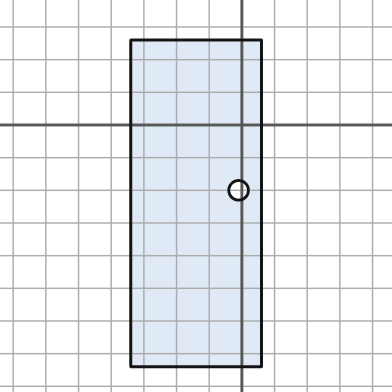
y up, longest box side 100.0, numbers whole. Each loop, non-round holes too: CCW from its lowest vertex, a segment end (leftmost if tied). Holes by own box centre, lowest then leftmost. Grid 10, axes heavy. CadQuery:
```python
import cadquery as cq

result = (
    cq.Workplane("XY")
    .moveTo(-34.0, -74.0)
    .lineTo(6.0, -74.0)
    .lineTo(6.0, 26.0)
    .lineTo(-34.0, 26.0)
    .close()
    .moveTo(-1.0, -20.0)
    .circle(3.0)
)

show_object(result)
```